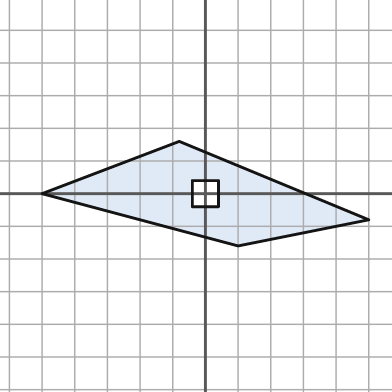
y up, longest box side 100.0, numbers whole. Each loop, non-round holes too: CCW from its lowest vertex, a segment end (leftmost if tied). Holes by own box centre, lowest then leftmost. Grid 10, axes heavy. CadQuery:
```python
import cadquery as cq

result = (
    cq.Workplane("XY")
    .moveTo(10.0, -16.0)
    .lineTo(50.0, -8.0)
    .lineTo(-8.0, 16.0)
    .lineTo(-50.0, 0.0)
    .close()
    .moveTo(-4.0, -4.0)
    .lineTo(4.0, -4.0)
    .lineTo(4.0, 4.0)
    .lineTo(-4.0, 4.0)
    .close()
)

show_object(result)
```